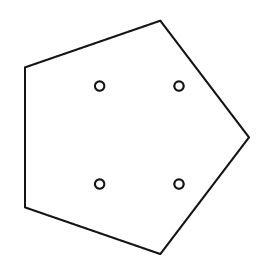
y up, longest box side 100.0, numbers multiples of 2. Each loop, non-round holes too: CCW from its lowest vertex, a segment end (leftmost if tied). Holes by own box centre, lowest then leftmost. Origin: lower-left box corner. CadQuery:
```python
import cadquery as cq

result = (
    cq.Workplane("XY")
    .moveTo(58.0, 0.0)
    .lineTo(96.0, 50.0)
    .lineTo(58.0, 100.0)
    .lineTo(0.0, 80.0)
    .lineTo(0.0, 20.0)
    .close()
    .moveTo(32.0, 30.0)
    .circle(2.0)
    .moveTo(66.0, 30.0)
    .circle(2.0)
    .moveTo(32.0, 72.0)
    .circle(2.0)
    .moveTo(66.0, 72.0)
    .circle(2.0)
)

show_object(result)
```